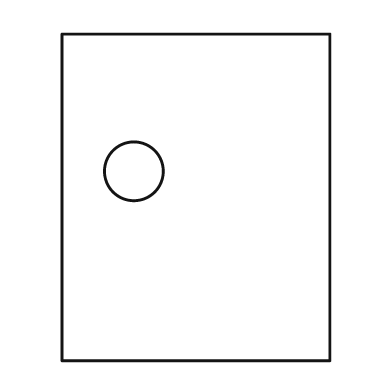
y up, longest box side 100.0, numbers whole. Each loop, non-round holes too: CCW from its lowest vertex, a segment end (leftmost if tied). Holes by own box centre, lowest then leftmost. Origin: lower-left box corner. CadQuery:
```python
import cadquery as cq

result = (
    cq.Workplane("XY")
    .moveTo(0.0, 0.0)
    .lineTo(82.0, 0.0)
    .lineTo(82.0, 100.0)
    .lineTo(0.0, 100.0)
    .close()
    .moveTo(22.0, 58.0)
    .circle(9.0)
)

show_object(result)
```